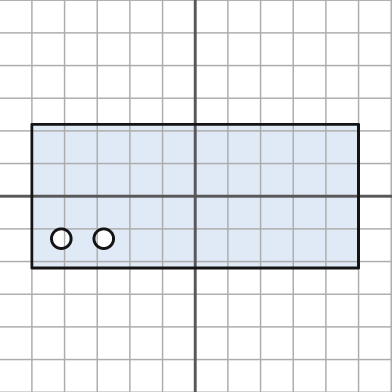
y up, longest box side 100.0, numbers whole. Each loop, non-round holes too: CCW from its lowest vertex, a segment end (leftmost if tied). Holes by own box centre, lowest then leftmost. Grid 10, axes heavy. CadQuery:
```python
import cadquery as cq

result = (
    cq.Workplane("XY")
    .moveTo(-50.0, -22.0)
    .lineTo(50.0, -22.0)
    .lineTo(50.0, 22.0)
    .lineTo(-50.0, 22.0)
    .close()
    .moveTo(-41.0, -13.0)
    .circle(3.0)
    .moveTo(-28.0, -13.0)
    .circle(3.0)
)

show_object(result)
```